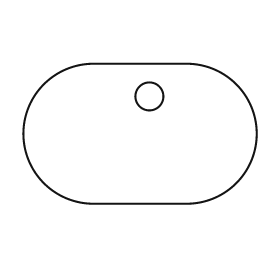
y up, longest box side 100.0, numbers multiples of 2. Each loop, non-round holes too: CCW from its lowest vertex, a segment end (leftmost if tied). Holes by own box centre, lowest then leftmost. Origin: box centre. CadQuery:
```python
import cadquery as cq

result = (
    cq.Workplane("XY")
    .moveTo(-20.0, -30.0)
    .lineTo(20.0, -30.0)
    .threePointArc((50.0, 0.0), (20.0, 30.0))
    .lineTo(-20.0, 30.0)
    .threePointArc((-50.0, 0.0), (-20.0, -30.0))
    .close()
    .moveTo(4.0, 16.0)
    .circle(6.0)
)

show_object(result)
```